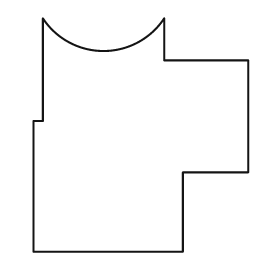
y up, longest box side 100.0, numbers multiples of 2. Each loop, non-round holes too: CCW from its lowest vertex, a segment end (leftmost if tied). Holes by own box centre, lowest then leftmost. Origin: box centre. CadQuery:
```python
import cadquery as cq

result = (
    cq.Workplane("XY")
    .moveTo(-46.0, -50.0)
    .lineTo(18.0, -50.0)
    .lineTo(18.0, -16.0)
    .lineTo(46.0, -16.0)
    .lineTo(46.0, 32.0)
    .lineTo(10.0, 32.0)
    .lineTo(10.0, 50.0)
    .threePointArc((-16.0, 36.0), (-42.0, 50.0))
    .lineTo(-42.0, 6.0)
    .lineTo(-46.0, 6.0)
    .close()
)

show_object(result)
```